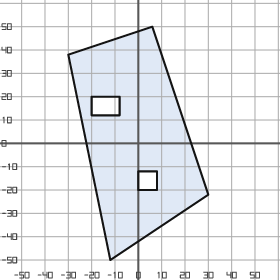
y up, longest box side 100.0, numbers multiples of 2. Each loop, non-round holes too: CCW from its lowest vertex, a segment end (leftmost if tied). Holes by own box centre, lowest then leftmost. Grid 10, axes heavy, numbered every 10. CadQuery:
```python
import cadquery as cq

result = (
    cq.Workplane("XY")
    .moveTo(-12.0, -50.0)
    .lineTo(30.0, -22.0)
    .lineTo(6.0, 50.0)
    .lineTo(-30.0, 38.0)
    .close()
    .moveTo(0.0, -20.0)
    .lineTo(8.0, -20.0)
    .lineTo(8.0, -12.0)
    .lineTo(0.0, -12.0)
    .close()
    .moveTo(-20.0, 12.0)
    .lineTo(-8.0, 12.0)
    .lineTo(-8.0, 20.0)
    .lineTo(-20.0, 20.0)
    .close()
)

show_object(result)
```